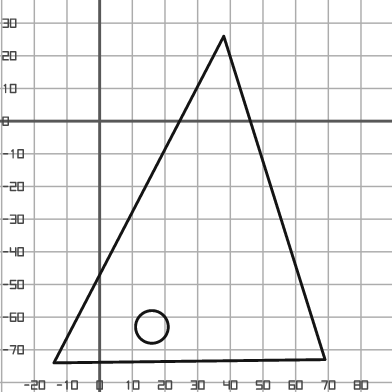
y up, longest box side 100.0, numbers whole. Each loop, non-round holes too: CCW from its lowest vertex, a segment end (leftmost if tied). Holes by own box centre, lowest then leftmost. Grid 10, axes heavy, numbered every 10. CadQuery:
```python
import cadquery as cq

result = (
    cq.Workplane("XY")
    .moveTo(-14.0, -74.0)
    .lineTo(69.0, -73.0)
    .lineTo(38.0, 26.0)
    .close()
    .moveTo(16.0, -63.0)
    .circle(5.0)
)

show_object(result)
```